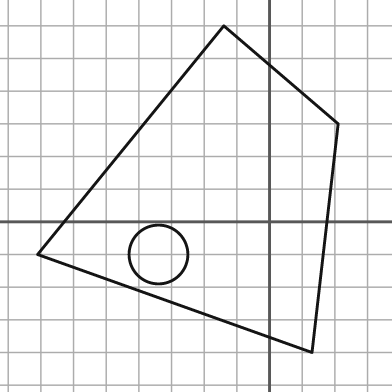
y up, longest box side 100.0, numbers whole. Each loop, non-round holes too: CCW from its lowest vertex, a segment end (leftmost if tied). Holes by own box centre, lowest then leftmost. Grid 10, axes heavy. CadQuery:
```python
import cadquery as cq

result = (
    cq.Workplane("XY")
    .moveTo(13.0, -40.0)
    .lineTo(21.0, 30.0)
    .lineTo(-14.0, 60.0)
    .lineTo(-71.0, -10.0)
    .close()
    .moveTo(-34.0, -10.0)
    .circle(9.0)
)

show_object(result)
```